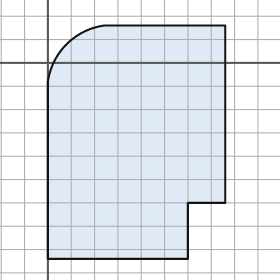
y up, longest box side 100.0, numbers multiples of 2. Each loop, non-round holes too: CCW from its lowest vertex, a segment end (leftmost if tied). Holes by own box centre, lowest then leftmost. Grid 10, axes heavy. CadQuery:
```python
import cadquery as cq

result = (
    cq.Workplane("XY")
    .moveTo(0.0, -84.0)
    .lineTo(60.0, -84.0)
    .lineTo(60.0, -60.0)
    .lineTo(76.0, -60.0)
    .lineTo(76.0, 16.0)
    .lineTo(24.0, 16.0)
    .threePointArc((8.0, 8.0), (0.0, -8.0))
    .close()
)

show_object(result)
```